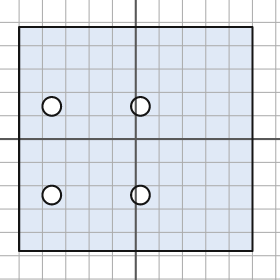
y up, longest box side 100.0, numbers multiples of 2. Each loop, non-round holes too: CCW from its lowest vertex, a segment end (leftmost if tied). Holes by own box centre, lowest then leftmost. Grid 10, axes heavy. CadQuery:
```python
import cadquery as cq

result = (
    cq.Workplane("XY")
    .moveTo(-50.0, -48.0)
    .lineTo(50.0, -48.0)
    .lineTo(50.0, 48.0)
    .lineTo(-50.0, 48.0)
    .close()
    .moveTo(-36.0, -24.0)
    .circle(4.0)
    .moveTo(2.0, -24.0)
    .circle(4.0)
    .moveTo(-36.0, 14.0)
    .circle(4.0)
    .moveTo(2.0, 14.0)
    .circle(4.0)
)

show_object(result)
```